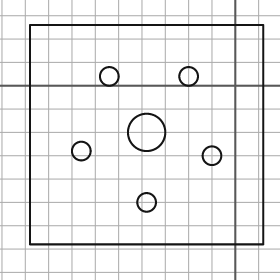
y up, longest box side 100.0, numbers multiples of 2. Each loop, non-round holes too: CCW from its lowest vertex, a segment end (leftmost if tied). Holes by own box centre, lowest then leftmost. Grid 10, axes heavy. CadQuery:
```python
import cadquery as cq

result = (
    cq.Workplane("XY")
    .moveTo(-88.0, -68.0)
    .lineTo(12.0, -68.0)
    .lineTo(12.0, 26.0)
    .lineTo(-88.0, 26.0)
    .close()
    .moveTo(-38.0, -50.0)
    .circle(4.0)
    .moveTo(-10.0, -30.0)
    .circle(4.0)
    .moveTo(-66.0, -28.0)
    .circle(4.0)
    .moveTo(-38.0, -20.0)
    .circle(8.0)
    .moveTo(-54.0, 4.0)
    .circle(4.0)
    .moveTo(-20.0, 4.0)
    .circle(4.0)
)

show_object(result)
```